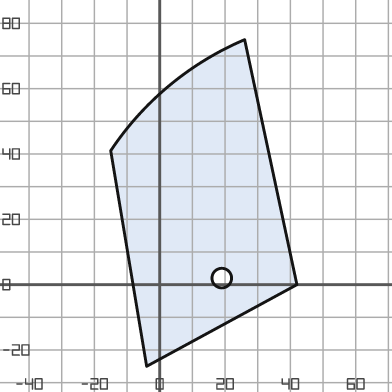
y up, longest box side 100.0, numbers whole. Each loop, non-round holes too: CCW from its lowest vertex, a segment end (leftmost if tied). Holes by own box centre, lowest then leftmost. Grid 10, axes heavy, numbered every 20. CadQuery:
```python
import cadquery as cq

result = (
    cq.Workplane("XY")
    .moveTo(-4.0, -25.0)
    .lineTo(42.0, 0.0)
    .lineTo(26.0, 75.0)
    .threePointArc((3.0, 61.0), (-15.0, 41.0))
    .close()
    .moveTo(19.0, 2.0)
    .circle(3.0)
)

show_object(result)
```